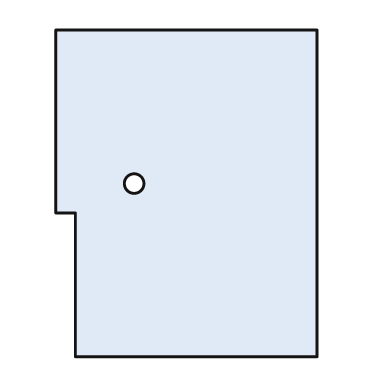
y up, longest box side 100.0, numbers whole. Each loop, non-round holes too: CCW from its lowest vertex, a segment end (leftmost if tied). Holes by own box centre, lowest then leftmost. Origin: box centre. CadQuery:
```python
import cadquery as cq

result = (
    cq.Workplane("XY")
    .moveTo(-34.0, -50.0)
    .lineTo(40.0, -50.0)
    .lineTo(40.0, 50.0)
    .lineTo(-40.0, 50.0)
    .lineTo(-40.0, -6.0)
    .lineTo(-34.0, -6.0)
    .close()
    .moveTo(-16.0, 3.0)
    .circle(3.0)
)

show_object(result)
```